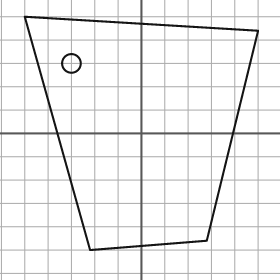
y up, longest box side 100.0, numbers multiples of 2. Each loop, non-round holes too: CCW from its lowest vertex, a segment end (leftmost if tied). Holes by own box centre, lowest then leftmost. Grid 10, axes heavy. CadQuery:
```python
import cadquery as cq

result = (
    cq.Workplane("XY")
    .moveTo(-22.0, -50.0)
    .lineTo(28.0, -46.0)
    .lineTo(50.0, 44.0)
    .lineTo(-50.0, 50.0)
    .close()
    .moveTo(-30.0, 30.0)
    .circle(4.0)
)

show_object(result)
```